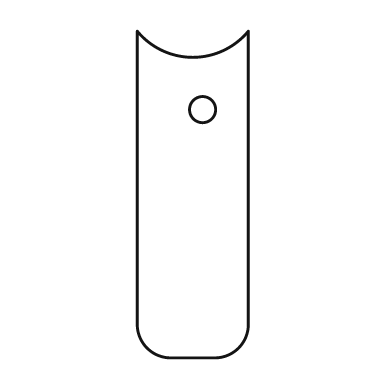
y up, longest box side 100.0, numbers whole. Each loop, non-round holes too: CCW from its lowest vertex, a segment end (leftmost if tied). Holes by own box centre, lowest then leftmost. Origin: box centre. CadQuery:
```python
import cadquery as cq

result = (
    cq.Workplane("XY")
    .moveTo(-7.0, -50.0)
    .lineTo(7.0, -50.0)
    .threePointArc((14.0, -47.0), (17.0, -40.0))
    .lineTo(17.0, 50.0)
    .threePointArc((0.0, 42.0), (-17.0, 50.0))
    .lineTo(-17.0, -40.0)
    .threePointArc((-14.0, -47.0), (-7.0, -50.0))
    .close()
    .moveTo(3.0, 26.0)
    .circle(4.0)
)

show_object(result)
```